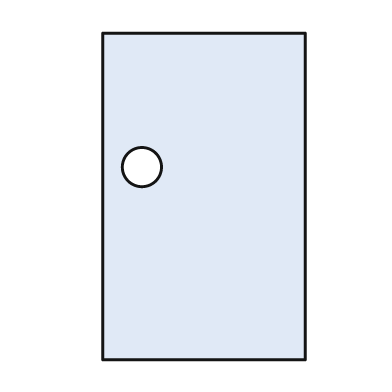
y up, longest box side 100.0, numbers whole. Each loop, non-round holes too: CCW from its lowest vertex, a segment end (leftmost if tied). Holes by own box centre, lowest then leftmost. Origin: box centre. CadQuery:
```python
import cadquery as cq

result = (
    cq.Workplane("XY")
    .moveTo(-31.0, -50.0)
    .lineTo(31.0, -50.0)
    .lineTo(31.0, 50.0)
    .lineTo(-31.0, 50.0)
    .close()
    .moveTo(-19.0, 9.0)
    .circle(6.0)
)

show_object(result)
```